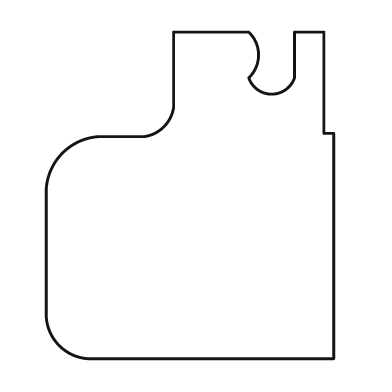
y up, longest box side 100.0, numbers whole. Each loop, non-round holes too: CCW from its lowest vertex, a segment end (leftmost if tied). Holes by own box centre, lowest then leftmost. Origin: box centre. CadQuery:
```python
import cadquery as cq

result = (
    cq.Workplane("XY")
    .moveTo(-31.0, -50.0)
    .lineTo(44.0, -50.0)
    .lineTo(44.0, 19.0)
    .lineTo(41.0, 19.0)
    .lineTo(41.0, 50.0)
    .lineTo(32.0, 50.0)
    .lineTo(32.0, 36.0)
    .threePointArc((25.0, 31.0), (18.0, 36.0))
    .threePointArc((21.0, 43.0), (18.0, 50.0))
    .lineTo(-5.0, 50.0)
    .lineTo(-5.0, 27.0)
    .threePointArc((-8.0, 21.0), (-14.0, 18.0))
    .lineTo(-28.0, 18.0)
    .threePointArc((-39.0, 13.0), (-44.0, 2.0))
    .lineTo(-44.0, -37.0)
    .threePointArc((-40.0, -46.0), (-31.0, -50.0))
    .close()
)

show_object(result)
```